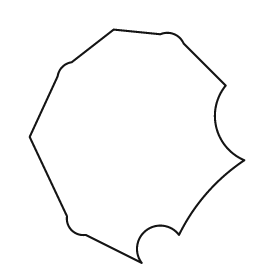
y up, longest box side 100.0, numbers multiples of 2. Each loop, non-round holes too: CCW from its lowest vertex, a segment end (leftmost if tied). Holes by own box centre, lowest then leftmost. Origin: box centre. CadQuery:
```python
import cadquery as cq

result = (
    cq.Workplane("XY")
    .moveTo(2.0, -50.0)
    .threePointArc((4.0, -36.0), (18.0, -38.0))
    .threePointArc((30.0, -20.0), (46.0, -6.0))
    .threePointArc((34.0, 8.0), (38.0, 26.0))
    .lineTo(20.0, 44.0)
    .threePointArc((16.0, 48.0), (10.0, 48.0))
    .lineTo(-10.0, 50.0)
    .lineTo(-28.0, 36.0)
    .threePointArc((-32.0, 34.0), (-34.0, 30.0))
    .lineTo(-46.0, 4.0)
    .lineTo(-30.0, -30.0)
    .threePointArc((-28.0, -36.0), (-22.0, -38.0))
    .close()
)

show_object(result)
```